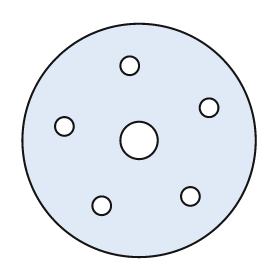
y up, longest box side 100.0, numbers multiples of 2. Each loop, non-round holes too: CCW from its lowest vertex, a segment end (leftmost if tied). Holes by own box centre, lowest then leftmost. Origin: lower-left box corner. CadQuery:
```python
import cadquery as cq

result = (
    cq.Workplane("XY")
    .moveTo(50.0, 50.0)
    .circle(50.0)
    .moveTo(34.0, 22.0)
    .circle(4.0)
    .moveTo(72.0, 26.0)
    .circle(4.0)
    .moveTo(50.0, 50.0)
    .circle(8.0)
    .moveTo(18.0, 56.0)
    .circle(4.0)
    .moveTo(80.0, 64.0)
    .circle(4.0)
    .moveTo(46.0, 82.0)
    .circle(4.0)
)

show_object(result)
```